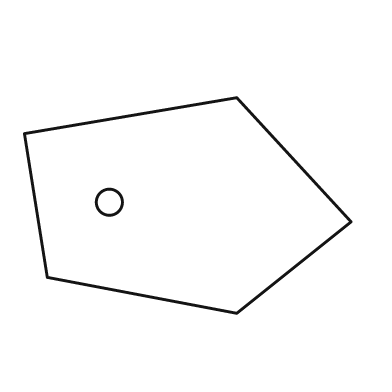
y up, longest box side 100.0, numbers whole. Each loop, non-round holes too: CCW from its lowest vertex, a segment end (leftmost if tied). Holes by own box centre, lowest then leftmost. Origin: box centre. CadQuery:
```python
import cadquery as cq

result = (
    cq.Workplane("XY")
    .moveTo(15.0, -33.0)
    .lineTo(50.0, -5.0)
    .lineTo(15.0, 33.0)
    .lineTo(-50.0, 22.0)
    .lineTo(-43.0, -22.0)
    .close()
    .moveTo(-24.0, 1.0)
    .circle(4.0)
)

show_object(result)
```